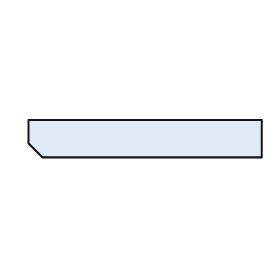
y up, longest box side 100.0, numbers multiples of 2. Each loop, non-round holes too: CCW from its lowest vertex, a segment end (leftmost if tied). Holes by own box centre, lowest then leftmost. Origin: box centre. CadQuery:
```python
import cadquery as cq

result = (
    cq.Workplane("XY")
    .moveTo(-44.0, -8.0)
    .lineTo(50.0, -8.0)
    .lineTo(50.0, 8.0)
    .lineTo(-50.0, 8.0)
    .lineTo(-50.0, -2.0)
    .close()
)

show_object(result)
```